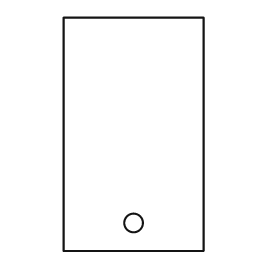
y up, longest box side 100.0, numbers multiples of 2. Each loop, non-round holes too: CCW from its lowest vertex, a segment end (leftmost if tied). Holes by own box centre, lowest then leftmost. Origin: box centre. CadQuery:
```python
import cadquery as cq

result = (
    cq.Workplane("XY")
    .moveTo(-30.0, -50.0)
    .lineTo(30.0, -50.0)
    .lineTo(30.0, 50.0)
    .lineTo(-30.0, 50.0)
    .close()
    .moveTo(0.0, -38.0)
    .circle(4.0)
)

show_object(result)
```